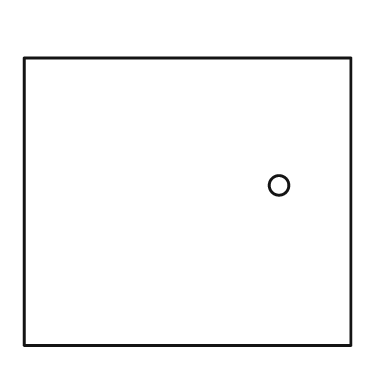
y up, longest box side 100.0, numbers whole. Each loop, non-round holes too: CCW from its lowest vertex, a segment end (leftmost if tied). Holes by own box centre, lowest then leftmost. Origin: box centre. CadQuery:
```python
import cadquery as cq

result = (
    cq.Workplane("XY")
    .moveTo(-50.0, -44.0)
    .lineTo(50.0, -44.0)
    .lineTo(50.0, 44.0)
    .lineTo(-50.0, 44.0)
    .close()
    .moveTo(28.0, 5.0)
    .circle(3.0)
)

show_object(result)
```